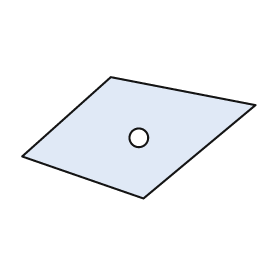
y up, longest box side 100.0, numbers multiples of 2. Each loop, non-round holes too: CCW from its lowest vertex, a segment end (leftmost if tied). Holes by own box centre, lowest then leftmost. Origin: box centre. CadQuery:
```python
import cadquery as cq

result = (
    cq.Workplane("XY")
    .moveTo(2.0, -26.0)
    .lineTo(50.0, 14.0)
    .lineTo(-12.0, 26.0)
    .lineTo(-50.0, -8.0)
    .close()
    .moveTo(0.0, 0.0)
    .circle(4.0)
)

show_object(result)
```